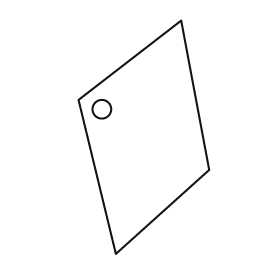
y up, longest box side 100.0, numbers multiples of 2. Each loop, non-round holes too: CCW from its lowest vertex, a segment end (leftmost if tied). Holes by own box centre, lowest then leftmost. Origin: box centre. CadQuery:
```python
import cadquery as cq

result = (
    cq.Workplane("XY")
    .moveTo(-12.0, -50.0)
    .lineTo(28.0, -14.0)
    .lineTo(16.0, 50.0)
    .lineTo(-28.0, 16.0)
    .close()
    .moveTo(-18.0, 12.0)
    .circle(4.0)
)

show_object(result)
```